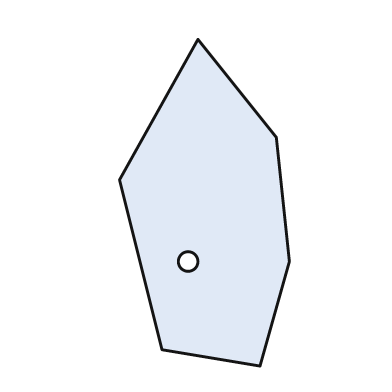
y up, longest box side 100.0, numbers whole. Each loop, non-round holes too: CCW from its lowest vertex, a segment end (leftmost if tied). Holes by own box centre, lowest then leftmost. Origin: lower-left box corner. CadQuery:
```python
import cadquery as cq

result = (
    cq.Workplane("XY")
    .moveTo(43.0, 0.0)
    .lineTo(52.0, 32.0)
    .lineTo(48.0, 70.0)
    .lineTo(24.0, 100.0)
    .lineTo(0.0, 57.0)
    .lineTo(13.0, 5.0)
    .close()
    .moveTo(21.0, 32.0)
    .circle(3.0)
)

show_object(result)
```